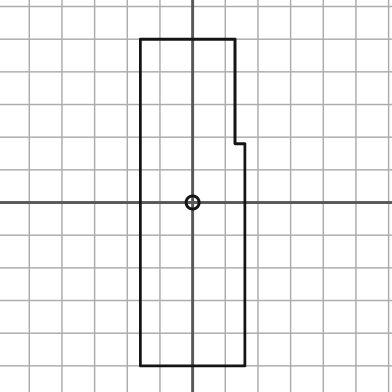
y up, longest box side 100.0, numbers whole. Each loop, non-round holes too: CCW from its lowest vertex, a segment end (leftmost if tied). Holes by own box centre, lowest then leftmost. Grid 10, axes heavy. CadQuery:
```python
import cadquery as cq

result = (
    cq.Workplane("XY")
    .moveTo(-16.0, -50.0)
    .lineTo(16.0, -50.0)
    .lineTo(16.0, 18.0)
    .lineTo(13.0, 18.0)
    .lineTo(13.0, 50.0)
    .lineTo(-16.0, 50.0)
    .close()
    .moveTo(0.0, 0.0)
    .circle(2.0)
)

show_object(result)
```